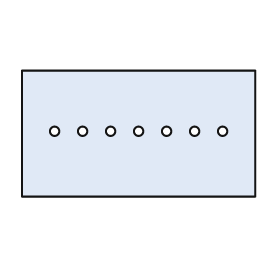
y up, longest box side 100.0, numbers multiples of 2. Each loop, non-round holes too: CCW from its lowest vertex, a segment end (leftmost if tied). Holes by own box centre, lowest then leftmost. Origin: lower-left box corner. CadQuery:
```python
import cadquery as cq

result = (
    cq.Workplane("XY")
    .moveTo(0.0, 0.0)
    .lineTo(100.0, 0.0)
    .lineTo(100.0, 54.0)
    .lineTo(0.0, 54.0)
    .close()
    .moveTo(14.0, 28.0)
    .circle(2.0)
    .moveTo(26.0, 28.0)
    .circle(2.0)
    .moveTo(38.0, 28.0)
    .circle(2.0)
    .moveTo(50.0, 28.0)
    .circle(2.0)
    .moveTo(62.0, 28.0)
    .circle(2.0)
    .moveTo(74.0, 28.0)
    .circle(2.0)
    .moveTo(86.0, 28.0)
    .circle(2.0)
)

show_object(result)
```